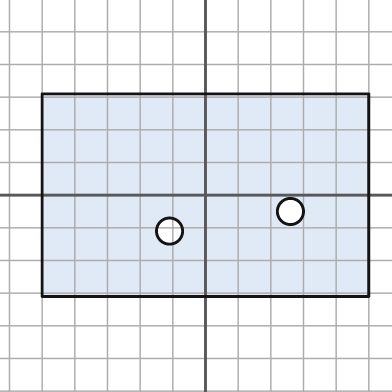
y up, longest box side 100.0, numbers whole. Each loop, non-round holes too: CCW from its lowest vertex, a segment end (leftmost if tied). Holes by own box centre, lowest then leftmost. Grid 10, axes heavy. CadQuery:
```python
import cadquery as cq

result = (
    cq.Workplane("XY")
    .moveTo(-50.0, -31.0)
    .lineTo(50.0, -31.0)
    .lineTo(50.0, 31.0)
    .lineTo(-50.0, 31.0)
    .close()
    .moveTo(-11.0, -11.0)
    .circle(4.0)
    .moveTo(26.0, -5.0)
    .circle(4.0)
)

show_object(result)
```